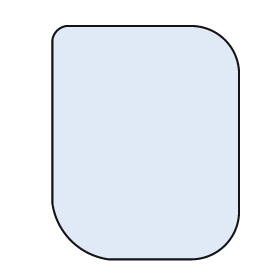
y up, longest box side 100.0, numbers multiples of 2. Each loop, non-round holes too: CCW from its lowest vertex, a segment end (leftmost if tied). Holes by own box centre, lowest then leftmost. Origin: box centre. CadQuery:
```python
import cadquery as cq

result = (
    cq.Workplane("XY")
    .moveTo(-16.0, -50.0)
    .lineTo(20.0, -50.0)
    .threePointArc((34.0, -44.0), (40.0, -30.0))
    .lineTo(40.0, 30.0)
    .threePointArc((34.0, 44.0), (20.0, 50.0))
    .lineTo(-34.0, 50.0)
    .threePointArc((-38.0, 48.0), (-40.0, 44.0))
    .lineTo(-40.0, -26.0)
    .threePointArc((-32.0, -42.0), (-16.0, -50.0))
    .close()
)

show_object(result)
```